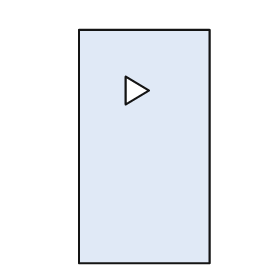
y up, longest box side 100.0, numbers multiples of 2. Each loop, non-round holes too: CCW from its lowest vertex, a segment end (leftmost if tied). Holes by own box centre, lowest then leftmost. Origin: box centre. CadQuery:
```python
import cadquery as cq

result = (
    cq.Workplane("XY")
    .moveTo(-28.0, -50.0)
    .lineTo(28.0, -50.0)
    .lineTo(28.0, 50.0)
    .lineTo(-28.0, 50.0)
    .close()
    .moveTo(-8.0, 18.0)
    .lineTo(2.0, 24.0)
    .lineTo(-8.0, 30.0)
    .close()
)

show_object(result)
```